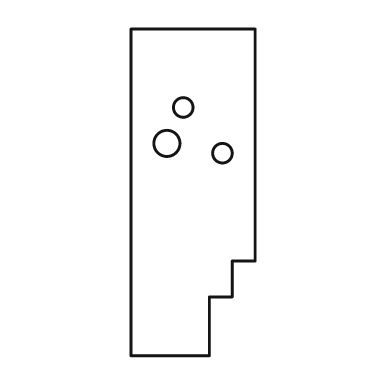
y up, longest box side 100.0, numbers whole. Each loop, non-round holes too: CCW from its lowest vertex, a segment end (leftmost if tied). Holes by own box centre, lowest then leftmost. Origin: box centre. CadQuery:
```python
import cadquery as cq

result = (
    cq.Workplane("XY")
    .moveTo(-19.0, -50.0)
    .lineTo(5.0, -50.0)
    .lineTo(5.0, -32.0)
    .lineTo(12.0, -32.0)
    .lineTo(12.0, -21.0)
    .lineTo(19.0, -21.0)
    .lineTo(19.0, 50.0)
    .lineTo(-19.0, 50.0)
    .close()
    .moveTo(9.0, 12.0)
    .circle(3.0)
    .moveTo(-8.0, 15.0)
    .circle(4.0)
    .moveTo(-3.0, 26.0)
    .circle(3.0)
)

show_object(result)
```